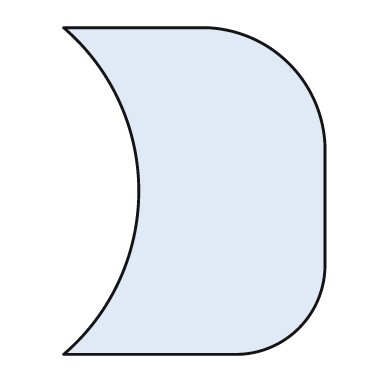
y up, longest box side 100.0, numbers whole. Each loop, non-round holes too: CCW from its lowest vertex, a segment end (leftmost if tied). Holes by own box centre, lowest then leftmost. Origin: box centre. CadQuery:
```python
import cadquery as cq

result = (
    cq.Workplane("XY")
    .moveTo(-40.0, -50.0)
    .lineTo(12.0, -50.0)
    .threePointArc((32.0, -42.0), (40.0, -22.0))
    .lineTo(40.0, 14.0)
    .threePointArc((29.0, 39.0), (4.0, 50.0))
    .lineTo(-40.0, 50.0)
    .threePointArc((-17.0, 0.0), (-40.0, -50.0))
    .close()
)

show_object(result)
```